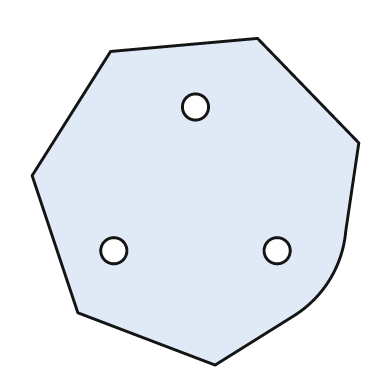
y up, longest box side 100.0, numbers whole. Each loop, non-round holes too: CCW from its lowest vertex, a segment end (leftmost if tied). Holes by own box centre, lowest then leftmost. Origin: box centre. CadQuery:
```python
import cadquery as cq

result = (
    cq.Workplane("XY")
    .moveTo(6.0, -50.0)
    .lineTo(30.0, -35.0)
    .threePointArc((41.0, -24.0), (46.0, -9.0))
    .lineTo(50.0, 18.0)
    .lineTo(19.0, 50.0)
    .lineTo(-26.0, 46.0)
    .lineTo(-50.0, 8.0)
    .lineTo(-36.0, -34.0)
    .close()
    .moveTo(-25.0, -15.0)
    .circle(4.0)
    .moveTo(25.0, -15.0)
    .circle(4.0)
    .moveTo(0.0, 29.0)
    .circle(4.0)
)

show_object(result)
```